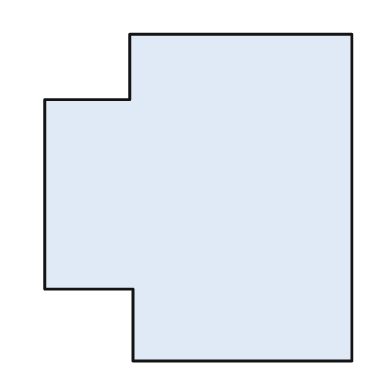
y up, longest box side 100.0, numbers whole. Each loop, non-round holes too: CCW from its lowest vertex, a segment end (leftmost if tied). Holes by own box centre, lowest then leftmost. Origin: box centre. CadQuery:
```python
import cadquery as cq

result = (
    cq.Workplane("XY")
    .moveTo(-20.0, -50.0)
    .lineTo(47.0, -50.0)
    .lineTo(47.0, 50.0)
    .lineTo(-21.0, 50.0)
    .lineTo(-21.0, 30.0)
    .lineTo(-47.0, 30.0)
    .lineTo(-47.0, -28.0)
    .lineTo(-20.0, -28.0)
    .close()
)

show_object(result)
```